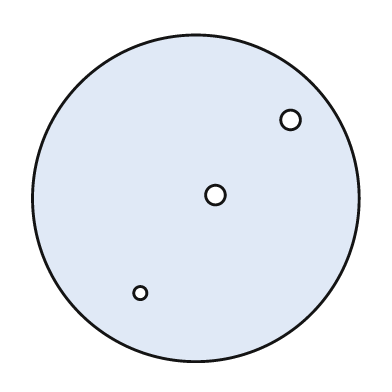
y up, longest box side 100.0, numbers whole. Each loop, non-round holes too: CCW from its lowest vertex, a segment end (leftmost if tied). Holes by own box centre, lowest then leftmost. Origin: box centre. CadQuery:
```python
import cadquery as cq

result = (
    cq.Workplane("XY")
    .moveTo(0.0, 0.0)
    .circle(50.0)
    .moveTo(-17.0, -29.0)
    .circle(2.0)
    .moveTo(6.0, 1.0)
    .circle(3.0)
    .moveTo(29.0, 24.0)
    .circle(3.0)
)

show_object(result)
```